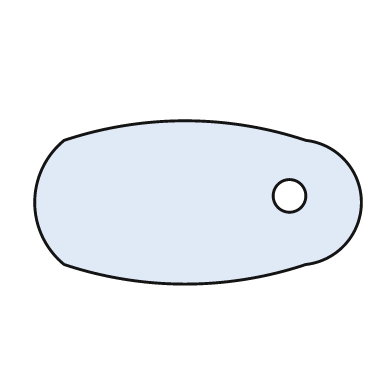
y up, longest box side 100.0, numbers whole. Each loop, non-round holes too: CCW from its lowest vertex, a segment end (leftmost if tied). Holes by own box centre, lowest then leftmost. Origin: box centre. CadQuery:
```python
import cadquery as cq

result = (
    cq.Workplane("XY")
    .moveTo(-41.0, -19.0)
    .threePointArc((-4.0, -25.0), (33.0, -19.0))
    .threePointArc((50.0, 0.0), (33.0, 19.0))
    .threePointArc((-4.0, 25.0), (-41.0, 19.0))
    .threePointArc((-50.0, 0.0), (-41.0, -19.0))
    .close()
    .moveTo(28.0, 2.0)
    .circle(5.0)
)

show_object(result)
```